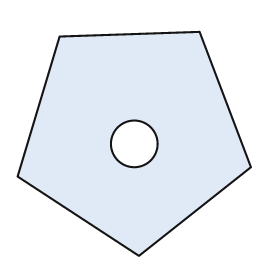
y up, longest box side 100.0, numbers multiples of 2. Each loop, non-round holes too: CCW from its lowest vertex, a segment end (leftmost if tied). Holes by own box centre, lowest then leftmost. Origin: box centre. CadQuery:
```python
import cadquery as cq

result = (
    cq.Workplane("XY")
    .moveTo(2.0, -48.0)
    .lineTo(50.0, -10.0)
    .lineTo(28.0, 48.0)
    .lineTo(-32.0, 46.0)
    .lineTo(-50.0, -14.0)
    .close()
    .moveTo(0.0, 0.0)
    .circle(10.0)
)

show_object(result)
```